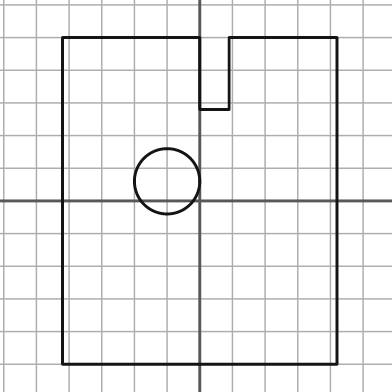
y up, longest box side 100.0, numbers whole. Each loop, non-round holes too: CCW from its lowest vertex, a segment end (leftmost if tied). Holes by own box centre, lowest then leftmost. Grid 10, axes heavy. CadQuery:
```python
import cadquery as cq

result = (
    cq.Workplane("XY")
    .moveTo(-42.0, -50.0)
    .lineTo(42.0, -50.0)
    .lineTo(42.0, 50.0)
    .lineTo(9.0, 50.0)
    .lineTo(9.0, 28.0)
    .lineTo(0.0, 28.0)
    .lineTo(0.0, 50.0)
    .lineTo(-42.0, 50.0)
    .close()
    .moveTo(-10.0, 6.0)
    .circle(10.0)
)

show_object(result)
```